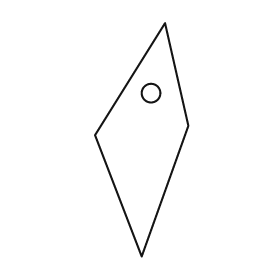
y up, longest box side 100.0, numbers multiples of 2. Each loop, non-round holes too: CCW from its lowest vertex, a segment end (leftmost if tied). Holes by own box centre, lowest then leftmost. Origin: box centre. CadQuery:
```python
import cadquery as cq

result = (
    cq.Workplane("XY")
    .moveTo(0.0, -50.0)
    .lineTo(20.0, 6.0)
    .lineTo(10.0, 50.0)
    .lineTo(-20.0, 2.0)
    .close()
    .moveTo(4.0, 20.0)
    .circle(4.0)
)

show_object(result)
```